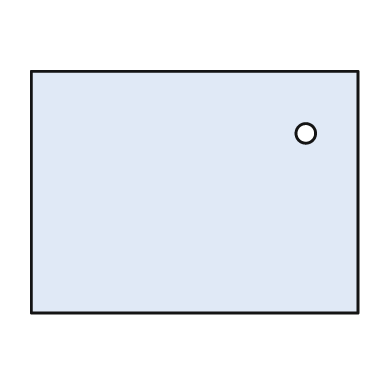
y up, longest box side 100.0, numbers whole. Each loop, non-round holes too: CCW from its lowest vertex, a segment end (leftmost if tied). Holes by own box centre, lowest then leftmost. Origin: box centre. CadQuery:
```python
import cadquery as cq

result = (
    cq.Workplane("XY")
    .moveTo(-50.0, -37.0)
    .lineTo(50.0, -37.0)
    .lineTo(50.0, 37.0)
    .lineTo(-50.0, 37.0)
    .close()
    .moveTo(34.0, 18.0)
    .circle(3.0)
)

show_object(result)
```